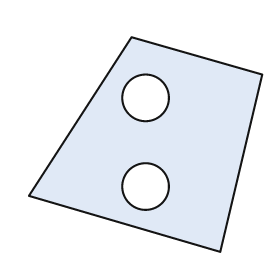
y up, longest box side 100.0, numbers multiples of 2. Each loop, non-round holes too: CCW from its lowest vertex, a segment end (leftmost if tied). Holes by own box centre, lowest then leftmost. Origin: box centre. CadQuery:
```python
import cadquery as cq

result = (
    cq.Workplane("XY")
    .moveTo(32.0, -46.0)
    .lineTo(50.0, 30.0)
    .lineTo(-6.0, 46.0)
    .lineTo(-50.0, -22.0)
    .close()
    .moveTo(0.0, -18.0)
    .circle(10.0)
    .moveTo(0.0, 20.0)
    .circle(10.0)
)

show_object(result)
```